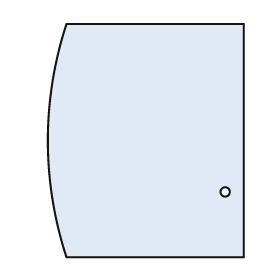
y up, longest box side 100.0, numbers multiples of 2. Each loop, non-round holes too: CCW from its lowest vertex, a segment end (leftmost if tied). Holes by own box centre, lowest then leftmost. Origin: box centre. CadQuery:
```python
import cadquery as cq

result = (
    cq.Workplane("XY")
    .moveTo(-34.0, -50.0)
    .lineTo(42.0, -50.0)
    .lineTo(42.0, 50.0)
    .lineTo(-34.0, 50.0)
    .threePointArc((-42.0, 0.0), (-34.0, -50.0))
    .close()
    .moveTo(34.0, -22.0)
    .circle(2.0)
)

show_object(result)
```